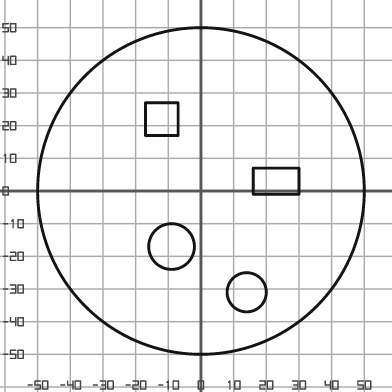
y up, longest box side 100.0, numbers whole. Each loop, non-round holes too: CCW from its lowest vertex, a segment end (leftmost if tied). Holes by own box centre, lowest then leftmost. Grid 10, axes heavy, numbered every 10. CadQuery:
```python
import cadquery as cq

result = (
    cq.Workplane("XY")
    .moveTo(0.0, 0.0)
    .circle(50.0)
    .moveTo(14.0, -31.0)
    .circle(6.0)
    .moveTo(-9.0, -17.0)
    .circle(7.0)
    .moveTo(16.0, -1.0)
    .lineTo(30.0, -1.0)
    .lineTo(30.0, 7.0)
    .lineTo(16.0, 7.0)
    .close()
    .moveTo(-17.0, 17.0)
    .lineTo(-7.0, 17.0)
    .lineTo(-7.0, 27.0)
    .lineTo(-17.0, 27.0)
    .close()
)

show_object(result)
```